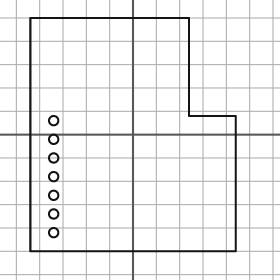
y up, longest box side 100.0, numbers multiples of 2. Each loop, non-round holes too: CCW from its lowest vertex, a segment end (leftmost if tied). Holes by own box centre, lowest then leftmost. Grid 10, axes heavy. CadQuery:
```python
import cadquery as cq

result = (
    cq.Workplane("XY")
    .moveTo(-44.0, -50.0)
    .lineTo(44.0, -50.0)
    .lineTo(44.0, 8.0)
    .lineTo(24.0, 8.0)
    .lineTo(24.0, 50.0)
    .lineTo(-44.0, 50.0)
    .close()
    .moveTo(-34.0, -42.0)
    .circle(2.0)
    .moveTo(-34.0, -34.0)
    .circle(2.0)
    .moveTo(-34.0, -26.0)
    .circle(2.0)
    .moveTo(-34.0, -18.0)
    .circle(2.0)
    .moveTo(-34.0, -10.0)
    .circle(2.0)
    .moveTo(-34.0, -2.0)
    .circle(2.0)
    .moveTo(-34.0, 6.0)
    .circle(2.0)
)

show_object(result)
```